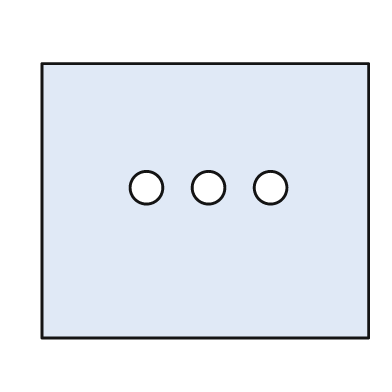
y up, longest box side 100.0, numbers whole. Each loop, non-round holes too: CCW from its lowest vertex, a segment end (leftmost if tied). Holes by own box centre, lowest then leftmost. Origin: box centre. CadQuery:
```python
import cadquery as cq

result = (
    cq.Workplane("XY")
    .moveTo(-50.0, -42.0)
    .lineTo(50.0, -42.0)
    .lineTo(50.0, 42.0)
    .lineTo(-50.0, 42.0)
    .close()
    .moveTo(-18.0, 4.0)
    .circle(5.0)
    .moveTo(1.0, 4.0)
    .circle(5.0)
    .moveTo(20.0, 4.0)
    .circle(5.0)
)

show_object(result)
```